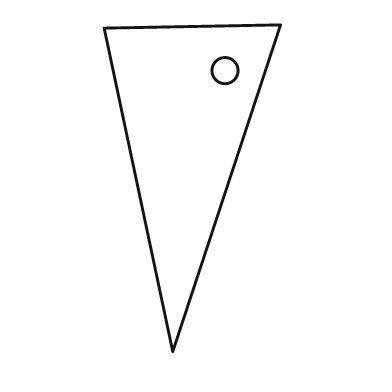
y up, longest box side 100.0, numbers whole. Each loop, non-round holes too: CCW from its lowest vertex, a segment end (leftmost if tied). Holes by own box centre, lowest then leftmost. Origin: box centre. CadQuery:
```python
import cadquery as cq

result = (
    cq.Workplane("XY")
    .moveTo(-6.0, -50.0)
    .lineTo(27.0, 50.0)
    .lineTo(-27.0, 49.0)
    .close()
    .moveTo(10.0, 36.0)
    .circle(4.0)
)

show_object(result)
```